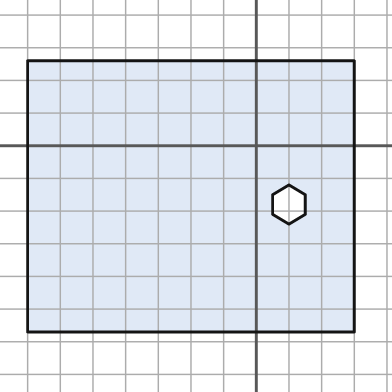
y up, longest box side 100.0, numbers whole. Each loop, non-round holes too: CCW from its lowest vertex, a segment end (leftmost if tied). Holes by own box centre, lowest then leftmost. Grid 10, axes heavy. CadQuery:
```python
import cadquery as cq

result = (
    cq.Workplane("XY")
    .moveTo(-70.0, -57.0)
    .lineTo(30.0, -57.0)
    .lineTo(30.0, 26.0)
    .lineTo(-70.0, 26.0)
    .close()
    .moveTo(10.0, -24.0)
    .lineTo(15.0, -21.0)
    .lineTo(15.0, -15.0)
    .lineTo(10.0, -12.0)
    .lineTo(5.0, -15.0)
    .lineTo(5.0, -21.0)
    .close()
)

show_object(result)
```